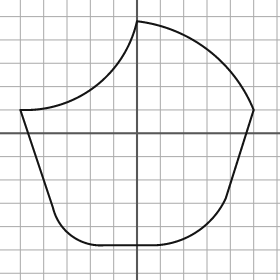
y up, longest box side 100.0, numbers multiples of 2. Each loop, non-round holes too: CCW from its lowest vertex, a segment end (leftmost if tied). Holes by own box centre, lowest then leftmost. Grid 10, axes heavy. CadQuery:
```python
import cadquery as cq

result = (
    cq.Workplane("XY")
    .moveTo(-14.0, -48.0)
    .lineTo(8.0, -48.0)
    .threePointArc((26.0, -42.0), (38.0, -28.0))
    .lineTo(50.0, 10.0)
    .threePointArc((30.0, 36.0), (0.0, 48.0))
    .threePointArc((-18.0, 20.0), (-50.0, 10.0))
    .lineTo(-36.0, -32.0)
    .threePointArc((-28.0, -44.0), (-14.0, -48.0))
    .close()
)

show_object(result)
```